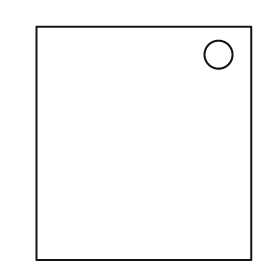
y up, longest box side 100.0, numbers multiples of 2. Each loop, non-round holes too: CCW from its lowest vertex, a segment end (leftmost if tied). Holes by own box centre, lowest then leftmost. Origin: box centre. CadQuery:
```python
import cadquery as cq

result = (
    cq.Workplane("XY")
    .moveTo(-46.0, -50.0)
    .lineTo(46.0, -50.0)
    .lineTo(46.0, 50.0)
    .lineTo(-46.0, 50.0)
    .close()
    .moveTo(32.0, 38.0)
    .circle(6.0)
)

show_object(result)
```